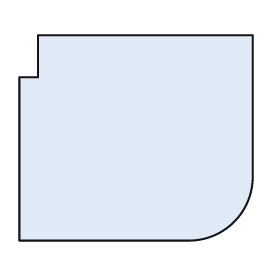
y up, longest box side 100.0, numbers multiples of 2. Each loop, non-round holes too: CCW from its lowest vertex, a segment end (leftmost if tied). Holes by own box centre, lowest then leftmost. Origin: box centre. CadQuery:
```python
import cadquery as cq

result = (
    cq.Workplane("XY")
    .moveTo(-50.0, -44.0)
    .lineTo(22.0, -44.0)
    .threePointArc((42.0, -36.0), (50.0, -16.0))
    .lineTo(50.0, 44.0)
    .lineTo(-42.0, 44.0)
    .lineTo(-42.0, 26.0)
    .lineTo(-50.0, 26.0)
    .close()
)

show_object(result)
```